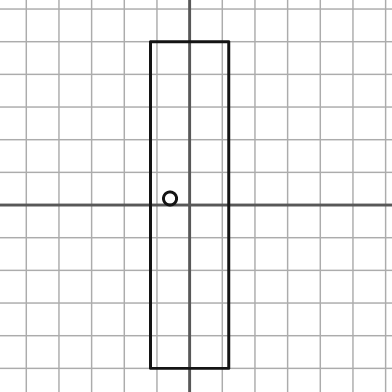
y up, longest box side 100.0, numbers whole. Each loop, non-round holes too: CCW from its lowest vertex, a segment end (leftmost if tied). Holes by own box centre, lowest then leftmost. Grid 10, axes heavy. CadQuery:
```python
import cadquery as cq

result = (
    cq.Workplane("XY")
    .moveTo(-12.0, -50.0)
    .lineTo(12.0, -50.0)
    .lineTo(12.0, 50.0)
    .lineTo(-12.0, 50.0)
    .close()
    .moveTo(-6.0, 2.0)
    .circle(2.0)
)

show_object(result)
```